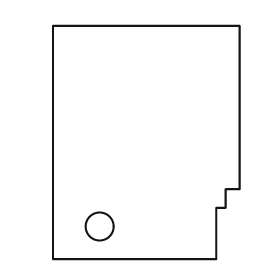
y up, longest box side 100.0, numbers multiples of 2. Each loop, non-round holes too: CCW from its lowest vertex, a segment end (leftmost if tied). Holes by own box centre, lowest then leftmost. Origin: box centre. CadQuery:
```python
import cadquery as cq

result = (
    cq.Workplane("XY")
    .moveTo(-40.0, -50.0)
    .lineTo(30.0, -50.0)
    .lineTo(30.0, -28.0)
    .lineTo(34.0, -28.0)
    .lineTo(34.0, -20.0)
    .lineTo(40.0, -20.0)
    .lineTo(40.0, 50.0)
    .lineTo(-40.0, 50.0)
    .close()
    .moveTo(-20.0, -36.0)
    .circle(6.0)
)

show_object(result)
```